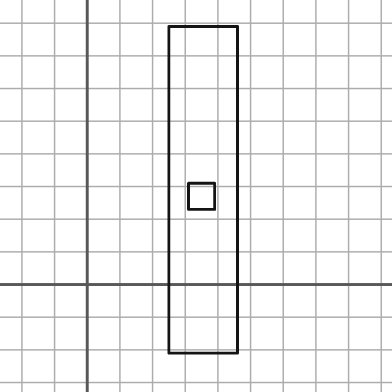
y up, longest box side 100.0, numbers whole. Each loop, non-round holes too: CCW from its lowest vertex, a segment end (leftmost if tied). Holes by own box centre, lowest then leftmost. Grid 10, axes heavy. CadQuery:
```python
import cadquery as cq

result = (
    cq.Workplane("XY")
    .moveTo(25.0, -21.0)
    .lineTo(46.0, -21.0)
    .lineTo(46.0, 79.0)
    .lineTo(25.0, 79.0)
    .close()
    .moveTo(31.0, 23.0)
    .lineTo(39.0, 23.0)
    .lineTo(39.0, 31.0)
    .lineTo(31.0, 31.0)
    .close()
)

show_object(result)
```